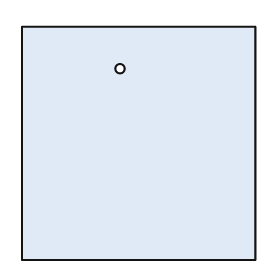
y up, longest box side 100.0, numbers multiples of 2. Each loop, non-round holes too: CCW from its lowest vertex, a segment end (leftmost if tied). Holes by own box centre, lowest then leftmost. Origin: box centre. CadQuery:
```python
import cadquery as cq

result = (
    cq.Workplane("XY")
    .moveTo(-50.0, -50.0)
    .lineTo(50.0, -50.0)
    .lineTo(50.0, 50.0)
    .lineTo(-50.0, 50.0)
    .close()
    .moveTo(-8.0, 32.0)
    .circle(2.0)
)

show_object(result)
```